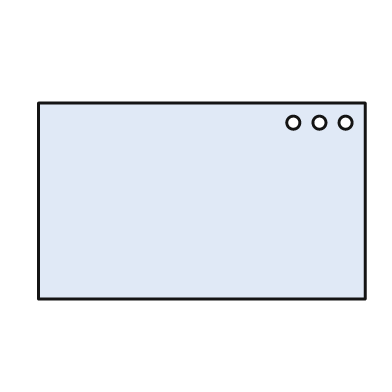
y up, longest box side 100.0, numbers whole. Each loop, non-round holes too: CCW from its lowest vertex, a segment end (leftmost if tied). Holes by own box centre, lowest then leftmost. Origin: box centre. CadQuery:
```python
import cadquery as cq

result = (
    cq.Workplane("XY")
    .moveTo(-50.0, -30.0)
    .lineTo(50.0, -30.0)
    .lineTo(50.0, 30.0)
    .lineTo(-50.0, 30.0)
    .close()
    .moveTo(28.0, 24.0)
    .circle(2.0)
    .moveTo(36.0, 24.0)
    .circle(2.0)
    .moveTo(44.0, 24.0)
    .circle(2.0)
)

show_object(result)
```